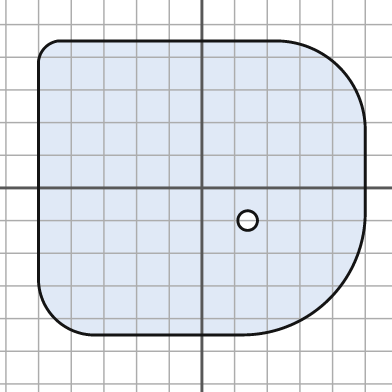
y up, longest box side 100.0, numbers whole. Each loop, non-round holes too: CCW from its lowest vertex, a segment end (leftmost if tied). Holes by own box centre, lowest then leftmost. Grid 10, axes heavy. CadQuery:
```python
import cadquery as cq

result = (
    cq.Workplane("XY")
    .moveTo(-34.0, -45.0)
    .lineTo(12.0, -45.0)
    .threePointArc((39.0, -34.0), (50.0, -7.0))
    .lineTo(50.0, 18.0)
    .threePointArc((42.0, 37.0), (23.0, 45.0))
    .lineTo(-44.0, 45.0)
    .threePointArc((-48.0, 43.0), (-50.0, 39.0))
    .lineTo(-50.0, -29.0)
    .threePointArc((-45.0, -40.0), (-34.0, -45.0))
    .close()
    .moveTo(14.0, -10.0)
    .circle(3.0)
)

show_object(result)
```